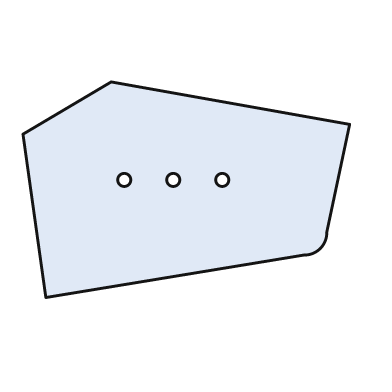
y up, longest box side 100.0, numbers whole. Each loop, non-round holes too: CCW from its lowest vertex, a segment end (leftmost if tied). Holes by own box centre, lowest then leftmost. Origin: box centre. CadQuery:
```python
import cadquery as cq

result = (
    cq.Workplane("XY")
    .moveTo(-43.0, -33.0)
    .lineTo(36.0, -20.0)
    .threePointArc((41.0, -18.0), (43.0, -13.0))
    .lineTo(50.0, 20.0)
    .lineTo(-23.0, 33.0)
    .lineTo(-50.0, 17.0)
    .close()
    .moveTo(-19.0, 3.0)
    .circle(2.0)
    .moveTo(-4.0, 3.0)
    .circle(2.0)
    .moveTo(11.0, 3.0)
    .circle(2.0)
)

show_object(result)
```